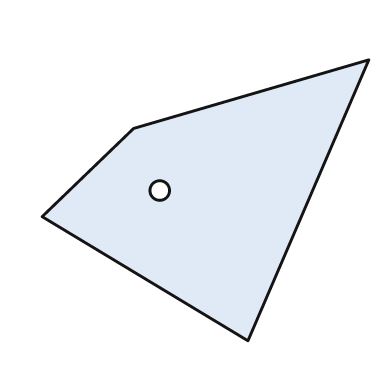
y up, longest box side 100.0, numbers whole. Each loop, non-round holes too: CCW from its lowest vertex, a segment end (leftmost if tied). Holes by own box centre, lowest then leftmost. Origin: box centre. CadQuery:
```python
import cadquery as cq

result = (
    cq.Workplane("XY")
    .moveTo(13.0, -43.0)
    .lineTo(50.0, 43.0)
    .lineTo(-22.0, 22.0)
    .lineTo(-50.0, -5.0)
    .close()
    .moveTo(-14.0, 3.0)
    .circle(3.0)
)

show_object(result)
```